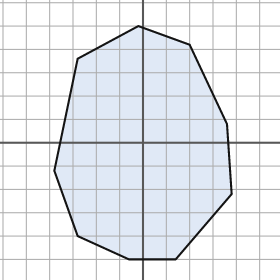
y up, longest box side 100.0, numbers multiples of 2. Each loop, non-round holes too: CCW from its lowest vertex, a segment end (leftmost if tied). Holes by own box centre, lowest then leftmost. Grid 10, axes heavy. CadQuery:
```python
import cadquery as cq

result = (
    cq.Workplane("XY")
    .moveTo(-6.0, -50.0)
    .lineTo(14.0, -50.0)
    .lineTo(38.0, -22.0)
    .lineTo(36.0, 8.0)
    .lineTo(20.0, 42.0)
    .lineTo(-2.0, 50.0)
    .lineTo(-28.0, 36.0)
    .lineTo(-38.0, -12.0)
    .lineTo(-28.0, -40.0)
    .close()
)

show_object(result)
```